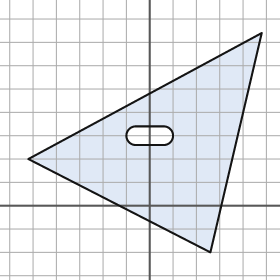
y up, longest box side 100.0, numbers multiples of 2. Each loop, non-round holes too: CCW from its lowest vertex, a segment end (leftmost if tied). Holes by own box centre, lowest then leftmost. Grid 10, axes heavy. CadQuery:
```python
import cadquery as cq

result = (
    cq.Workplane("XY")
    .moveTo(26.0, -20.0)
    .lineTo(48.0, 74.0)
    .lineTo(-52.0, 20.0)
    .close()
    .moveTo(-6.0, 26.0)
    .lineTo(6.0, 26.0)
    .threePointArc((10.0, 30.0), (6.0, 34.0))
    .lineTo(-6.0, 34.0)
    .threePointArc((-10.0, 30.0), (-6.0, 26.0))
    .close()
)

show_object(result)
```